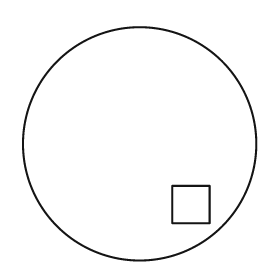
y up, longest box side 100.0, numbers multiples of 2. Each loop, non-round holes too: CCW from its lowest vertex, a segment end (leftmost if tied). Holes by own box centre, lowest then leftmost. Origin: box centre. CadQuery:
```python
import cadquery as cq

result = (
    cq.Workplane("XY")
    .moveTo(0.0, 0.0)
    .circle(50.0)
    .moveTo(14.0, -34.0)
    .lineTo(30.0, -34.0)
    .lineTo(30.0, -18.0)
    .lineTo(14.0, -18.0)
    .close()
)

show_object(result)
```